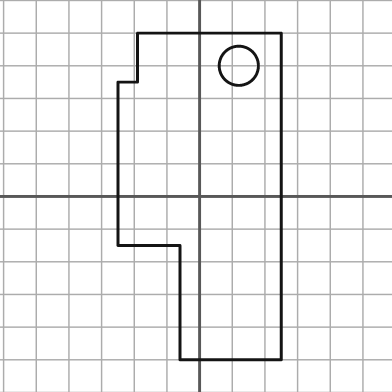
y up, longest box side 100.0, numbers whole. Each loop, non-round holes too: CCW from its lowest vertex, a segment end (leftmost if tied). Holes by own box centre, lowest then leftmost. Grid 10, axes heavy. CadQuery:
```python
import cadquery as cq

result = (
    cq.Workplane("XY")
    .moveTo(-6.0, -50.0)
    .lineTo(25.0, -50.0)
    .lineTo(25.0, 50.0)
    .lineTo(-19.0, 50.0)
    .lineTo(-19.0, 35.0)
    .lineTo(-25.0, 35.0)
    .lineTo(-25.0, -15.0)
    .lineTo(-6.0, -15.0)
    .close()
    .moveTo(12.0, 40.0)
    .circle(6.0)
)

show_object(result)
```